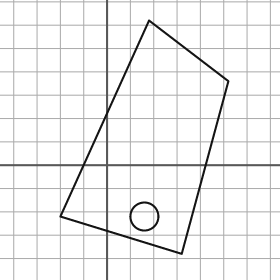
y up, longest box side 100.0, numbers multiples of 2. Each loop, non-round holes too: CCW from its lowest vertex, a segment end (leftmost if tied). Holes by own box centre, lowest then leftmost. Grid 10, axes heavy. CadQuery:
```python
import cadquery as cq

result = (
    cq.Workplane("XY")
    .moveTo(32.0, -38.0)
    .lineTo(52.0, 36.0)
    .lineTo(18.0, 62.0)
    .lineTo(-20.0, -22.0)
    .close()
    .moveTo(16.0, -22.0)
    .circle(6.0)
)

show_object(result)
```